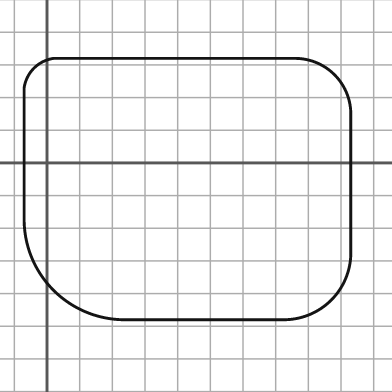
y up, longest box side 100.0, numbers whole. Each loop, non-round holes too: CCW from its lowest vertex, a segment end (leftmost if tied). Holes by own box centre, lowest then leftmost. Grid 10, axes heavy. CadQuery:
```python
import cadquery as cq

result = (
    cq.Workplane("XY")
    .moveTo(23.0, -48.0)
    .lineTo(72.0, -48.0)
    .threePointArc((87.0, -42.0), (93.0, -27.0))
    .lineTo(93.0, 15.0)
    .threePointArc((88.0, 27.0), (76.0, 32.0))
    .lineTo(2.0, 32.0)
    .threePointArc((-4.0, 29.0), (-7.0, 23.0))
    .lineTo(-7.0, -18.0)
    .threePointArc((2.0, -39.0), (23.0, -48.0))
    .close()
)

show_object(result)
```